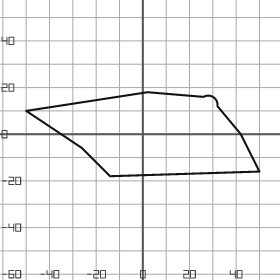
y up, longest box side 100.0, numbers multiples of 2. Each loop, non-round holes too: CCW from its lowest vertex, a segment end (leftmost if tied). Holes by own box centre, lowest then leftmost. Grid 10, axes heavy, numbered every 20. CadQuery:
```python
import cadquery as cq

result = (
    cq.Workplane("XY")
    .moveTo(-14.0, -18.0)
    .lineTo(50.0, -16.0)
    .lineTo(42.0, 0.0)
    .lineTo(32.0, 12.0)
    .threePointArc((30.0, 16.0), (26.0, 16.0))
    .lineTo(2.0, 18.0)
    .lineTo(-50.0, 10.0)
    .lineTo(-26.0, -6.0)
    .close()
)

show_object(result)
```